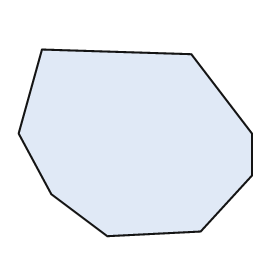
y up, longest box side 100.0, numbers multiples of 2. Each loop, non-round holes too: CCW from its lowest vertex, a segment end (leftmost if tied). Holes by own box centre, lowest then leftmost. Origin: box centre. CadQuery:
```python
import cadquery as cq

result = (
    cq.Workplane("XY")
    .moveTo(-12.0, -40.0)
    .lineTo(28.0, -38.0)
    .lineTo(50.0, -14.0)
    .lineTo(50.0, 4.0)
    .lineTo(24.0, 38.0)
    .lineTo(-40.0, 40.0)
    .lineTo(-50.0, 4.0)
    .lineTo(-36.0, -22.0)
    .close()
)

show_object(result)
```